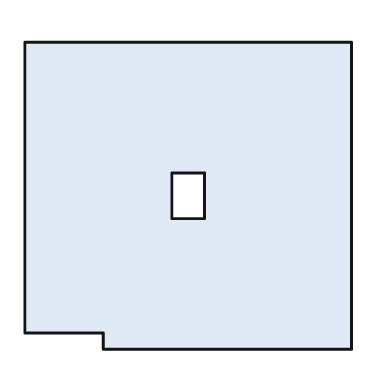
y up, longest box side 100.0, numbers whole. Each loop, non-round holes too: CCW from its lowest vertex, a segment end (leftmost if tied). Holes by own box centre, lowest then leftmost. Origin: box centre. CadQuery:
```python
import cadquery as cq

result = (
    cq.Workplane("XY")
    .moveTo(-26.0, -47.0)
    .lineTo(50.0, -47.0)
    .lineTo(50.0, 47.0)
    .lineTo(-50.0, 47.0)
    .lineTo(-50.0, -42.0)
    .lineTo(-26.0, -42.0)
    .close()
    .moveTo(-5.0, -7.0)
    .lineTo(5.0, -7.0)
    .lineTo(5.0, 7.0)
    .lineTo(-5.0, 7.0)
    .close()
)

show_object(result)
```